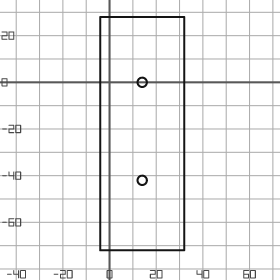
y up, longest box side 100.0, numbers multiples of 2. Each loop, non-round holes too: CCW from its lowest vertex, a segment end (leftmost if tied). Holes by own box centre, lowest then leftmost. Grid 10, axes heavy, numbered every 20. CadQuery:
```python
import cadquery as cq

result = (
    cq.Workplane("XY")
    .moveTo(-4.0, -72.0)
    .lineTo(32.0, -72.0)
    .lineTo(32.0, 28.0)
    .lineTo(-4.0, 28.0)
    .close()
    .moveTo(14.0, -42.0)
    .circle(2.0)
    .moveTo(14.0, 0.0)
    .circle(2.0)
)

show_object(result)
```